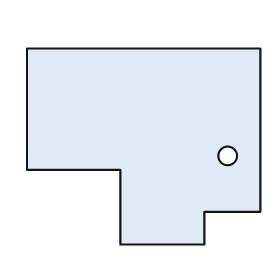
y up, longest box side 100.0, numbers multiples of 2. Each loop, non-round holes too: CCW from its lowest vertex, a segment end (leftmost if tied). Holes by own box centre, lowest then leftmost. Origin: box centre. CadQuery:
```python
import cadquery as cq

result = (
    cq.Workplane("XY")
    .moveTo(-10.0, -42.0)
    .lineTo(26.0, -42.0)
    .lineTo(26.0, -28.0)
    .lineTo(50.0, -28.0)
    .lineTo(50.0, 42.0)
    .lineTo(-50.0, 42.0)
    .lineTo(-50.0, -10.0)
    .lineTo(-10.0, -10.0)
    .close()
    .moveTo(36.0, -4.0)
    .circle(4.0)
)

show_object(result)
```